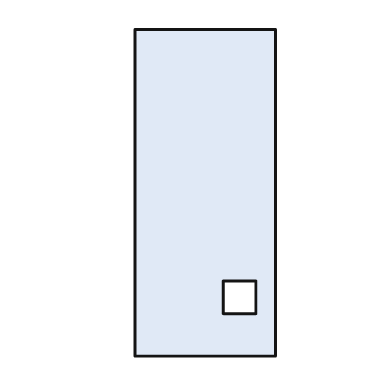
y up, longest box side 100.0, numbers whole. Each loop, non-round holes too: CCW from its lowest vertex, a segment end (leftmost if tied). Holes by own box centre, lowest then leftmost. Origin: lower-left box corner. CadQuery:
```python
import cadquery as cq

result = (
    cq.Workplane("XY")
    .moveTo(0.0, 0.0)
    .lineTo(43.0, 0.0)
    .lineTo(43.0, 100.0)
    .lineTo(0.0, 100.0)
    .close()
    .moveTo(27.0, 13.0)
    .lineTo(37.0, 13.0)
    .lineTo(37.0, 23.0)
    .lineTo(27.0, 23.0)
    .close()
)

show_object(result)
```